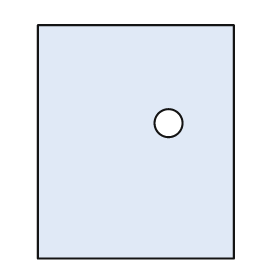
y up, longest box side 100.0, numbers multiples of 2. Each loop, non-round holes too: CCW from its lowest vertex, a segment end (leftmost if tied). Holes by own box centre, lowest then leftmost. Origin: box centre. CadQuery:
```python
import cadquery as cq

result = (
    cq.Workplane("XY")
    .moveTo(-42.0, -50.0)
    .lineTo(42.0, -50.0)
    .lineTo(42.0, 50.0)
    .lineTo(-42.0, 50.0)
    .close()
    .moveTo(14.0, 8.0)
    .circle(6.0)
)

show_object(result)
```